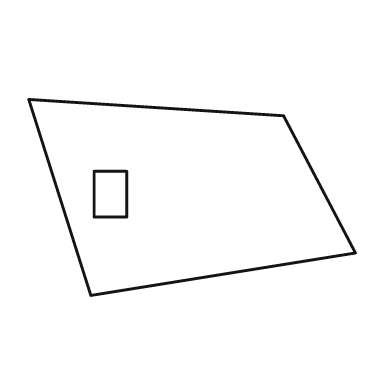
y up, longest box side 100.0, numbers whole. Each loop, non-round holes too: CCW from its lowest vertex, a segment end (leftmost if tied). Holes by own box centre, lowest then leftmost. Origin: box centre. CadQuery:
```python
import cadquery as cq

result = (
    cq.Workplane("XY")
    .moveTo(-31.0, -30.0)
    .lineTo(50.0, -17.0)
    .lineTo(28.0, 25.0)
    .lineTo(-50.0, 30.0)
    .close()
    .moveTo(-30.0, -6.0)
    .lineTo(-20.0, -6.0)
    .lineTo(-20.0, 8.0)
    .lineTo(-30.0, 8.0)
    .close()
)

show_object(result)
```